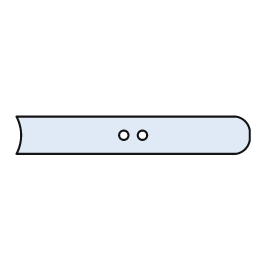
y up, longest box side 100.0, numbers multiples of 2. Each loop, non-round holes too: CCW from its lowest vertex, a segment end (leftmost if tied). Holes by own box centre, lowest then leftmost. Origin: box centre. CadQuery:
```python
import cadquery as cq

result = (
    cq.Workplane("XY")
    .moveTo(-50.0, -8.0)
    .lineTo(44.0, -8.0)
    .threePointArc((48.0, -6.0), (50.0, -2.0))
    .lineTo(50.0, 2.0)
    .threePointArc((48.0, 6.0), (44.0, 8.0))
    .lineTo(-50.0, 8.0)
    .threePointArc((-48.0, 0.0), (-50.0, -8.0))
    .close()
    .moveTo(-4.0, 0.0)
    .circle(2.0)
    .moveTo(4.0, 0.0)
    .circle(2.0)
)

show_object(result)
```